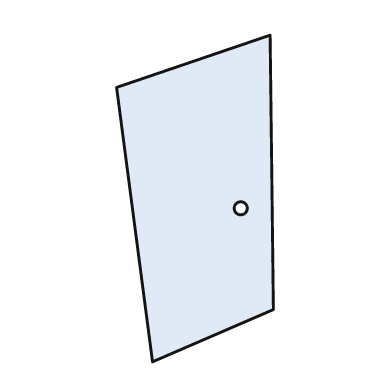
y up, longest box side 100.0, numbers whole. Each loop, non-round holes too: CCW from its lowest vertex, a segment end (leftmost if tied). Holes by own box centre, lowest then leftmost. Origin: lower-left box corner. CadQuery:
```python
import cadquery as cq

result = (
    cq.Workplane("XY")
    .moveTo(11.0, 0.0)
    .lineTo(48.0, 16.0)
    .lineTo(47.0, 100.0)
    .lineTo(0.0, 84.0)
    .close()
    .moveTo(38.0, 47.0)
    .circle(2.0)
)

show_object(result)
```